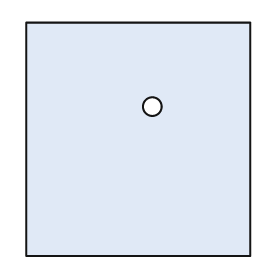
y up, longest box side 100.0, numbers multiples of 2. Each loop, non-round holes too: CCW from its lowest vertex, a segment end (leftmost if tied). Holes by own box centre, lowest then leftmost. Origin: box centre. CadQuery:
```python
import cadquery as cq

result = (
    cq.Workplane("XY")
    .moveTo(-48.0, -50.0)
    .lineTo(48.0, -50.0)
    .lineTo(48.0, 50.0)
    .lineTo(-48.0, 50.0)
    .close()
    .moveTo(6.0, 14.0)
    .circle(4.0)
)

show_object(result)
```